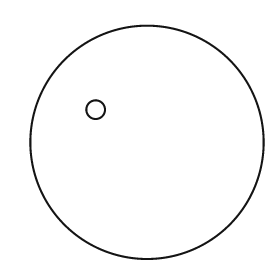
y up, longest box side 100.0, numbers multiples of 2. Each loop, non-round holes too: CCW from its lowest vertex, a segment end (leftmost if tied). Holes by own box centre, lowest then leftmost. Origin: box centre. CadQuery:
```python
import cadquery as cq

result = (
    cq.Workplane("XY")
    .moveTo(0.0, 0.0)
    .circle(50.0)
    .moveTo(-22.0, 14.0)
    .circle(4.0)
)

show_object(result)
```